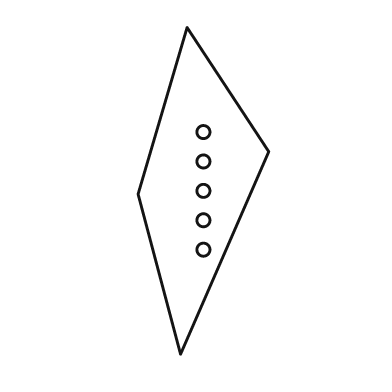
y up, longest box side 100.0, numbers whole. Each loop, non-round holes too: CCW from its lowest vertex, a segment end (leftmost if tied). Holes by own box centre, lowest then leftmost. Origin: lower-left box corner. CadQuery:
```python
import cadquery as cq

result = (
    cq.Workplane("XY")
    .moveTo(13.0, 0.0)
    .lineTo(40.0, 62.0)
    .lineTo(15.0, 100.0)
    .lineTo(0.0, 49.0)
    .close()
    .moveTo(20.0, 32.0)
    .circle(2.0)
    .moveTo(20.0, 41.0)
    .circle(2.0)
    .moveTo(20.0, 50.0)
    .circle(2.0)
    .moveTo(20.0, 59.0)
    .circle(2.0)
    .moveTo(20.0, 68.0)
    .circle(2.0)
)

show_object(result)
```